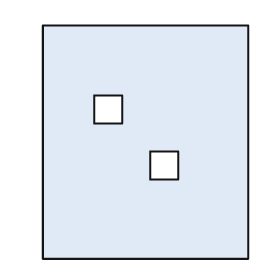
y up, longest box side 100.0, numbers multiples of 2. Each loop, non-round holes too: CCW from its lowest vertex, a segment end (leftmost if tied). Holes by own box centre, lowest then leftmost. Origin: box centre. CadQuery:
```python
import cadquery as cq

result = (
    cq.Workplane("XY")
    .moveTo(-44.0, -50.0)
    .lineTo(44.0, -50.0)
    .lineTo(44.0, 50.0)
    .lineTo(-44.0, 50.0)
    .close()
    .moveTo(2.0, -16.0)
    .lineTo(14.0, -16.0)
    .lineTo(14.0, -4.0)
    .lineTo(2.0, -4.0)
    .close()
    .moveTo(-22.0, 8.0)
    .lineTo(-10.0, 8.0)
    .lineTo(-10.0, 20.0)
    .lineTo(-22.0, 20.0)
    .close()
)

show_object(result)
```